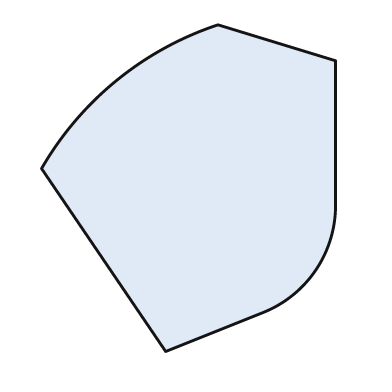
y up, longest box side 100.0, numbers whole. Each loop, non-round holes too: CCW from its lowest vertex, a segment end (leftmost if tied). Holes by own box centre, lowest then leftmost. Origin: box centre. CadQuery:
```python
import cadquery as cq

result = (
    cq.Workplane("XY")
    .moveTo(-7.0, -50.0)
    .lineTo(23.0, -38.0)
    .threePointArc((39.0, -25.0), (45.0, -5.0))
    .lineTo(45.0, 39.0)
    .lineTo(9.0, 50.0)
    .threePointArc((-22.0, 33.0), (-45.0, 6.0))
    .close()
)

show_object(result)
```